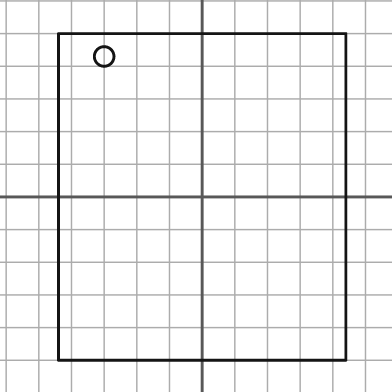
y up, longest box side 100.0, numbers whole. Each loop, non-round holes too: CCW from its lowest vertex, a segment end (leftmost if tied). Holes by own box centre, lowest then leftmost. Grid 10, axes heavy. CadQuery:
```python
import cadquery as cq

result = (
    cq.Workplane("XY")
    .moveTo(-44.0, -50.0)
    .lineTo(44.0, -50.0)
    .lineTo(44.0, 50.0)
    .lineTo(-44.0, 50.0)
    .close()
    .moveTo(-30.0, 43.0)
    .circle(3.0)
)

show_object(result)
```